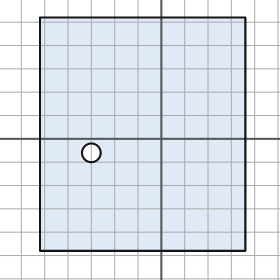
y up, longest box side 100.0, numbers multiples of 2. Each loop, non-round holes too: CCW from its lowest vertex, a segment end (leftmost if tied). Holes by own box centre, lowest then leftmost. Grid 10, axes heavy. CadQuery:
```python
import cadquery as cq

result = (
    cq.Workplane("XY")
    .moveTo(-52.0, -48.0)
    .lineTo(36.0, -48.0)
    .lineTo(36.0, 52.0)
    .lineTo(-52.0, 52.0)
    .close()
    .moveTo(-30.0, -6.0)
    .circle(4.0)
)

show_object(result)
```